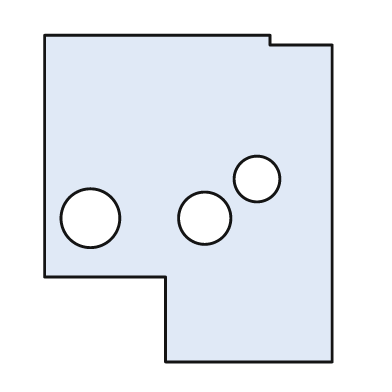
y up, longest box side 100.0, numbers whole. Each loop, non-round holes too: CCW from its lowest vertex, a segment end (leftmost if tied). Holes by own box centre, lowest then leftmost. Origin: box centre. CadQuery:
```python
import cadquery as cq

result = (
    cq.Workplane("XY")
    .moveTo(-7.0, -50.0)
    .lineTo(44.0, -50.0)
    .lineTo(44.0, 47.0)
    .lineTo(25.0, 47.0)
    .lineTo(25.0, 50.0)
    .lineTo(-44.0, 50.0)
    .lineTo(-44.0, -24.0)
    .lineTo(-7.0, -24.0)
    .close()
    .moveTo(-30.0, -6.0)
    .circle(9.0)
    .moveTo(5.0, -6.0)
    .circle(8.0)
    .moveTo(21.0, 6.0)
    .circle(7.0)
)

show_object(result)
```